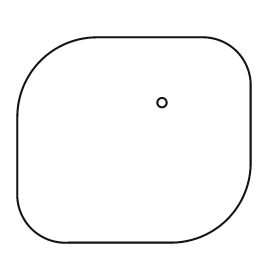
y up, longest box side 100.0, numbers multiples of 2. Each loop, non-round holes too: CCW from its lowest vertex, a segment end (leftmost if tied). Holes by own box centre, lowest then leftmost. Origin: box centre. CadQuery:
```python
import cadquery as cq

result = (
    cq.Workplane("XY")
    .moveTo(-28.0, -44.0)
    .lineTo(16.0, -44.0)
    .threePointArc((40.0, -34.0), (50.0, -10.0))
    .lineTo(50.0, 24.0)
    .threePointArc((44.0, 38.0), (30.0, 44.0))
    .lineTo(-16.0, 44.0)
    .threePointArc((-40.0, 34.0), (-50.0, 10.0))
    .lineTo(-50.0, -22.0)
    .threePointArc((-44.0, -38.0), (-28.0, -44.0))
    .close()
    .moveTo(12.0, 16.0)
    .circle(2.0)
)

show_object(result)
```